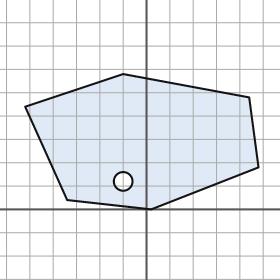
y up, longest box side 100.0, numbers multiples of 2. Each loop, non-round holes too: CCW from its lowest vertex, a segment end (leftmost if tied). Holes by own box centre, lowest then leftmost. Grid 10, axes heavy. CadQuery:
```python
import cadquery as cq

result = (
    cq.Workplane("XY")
    .moveTo(2.0, 0.0)
    .lineTo(48.0, 18.0)
    .lineTo(44.0, 48.0)
    .lineTo(-10.0, 58.0)
    .lineTo(-52.0, 44.0)
    .lineTo(-34.0, 4.0)
    .close()
    .moveTo(-10.0, 12.0)
    .circle(4.0)
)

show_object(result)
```